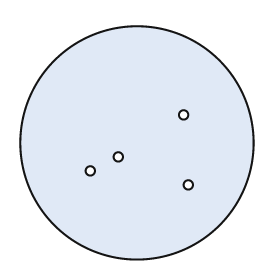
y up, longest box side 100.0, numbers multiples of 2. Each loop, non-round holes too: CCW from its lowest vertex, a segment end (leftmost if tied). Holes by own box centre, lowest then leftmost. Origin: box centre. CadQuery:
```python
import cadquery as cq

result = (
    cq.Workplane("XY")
    .moveTo(0.0, 0.0)
    .circle(50.0)
    .moveTo(22.0, -18.0)
    .circle(2.0)
    .moveTo(-20.0, -12.0)
    .circle(2.0)
    .moveTo(-8.0, -6.0)
    .circle(2.0)
    .moveTo(20.0, 12.0)
    .circle(2.0)
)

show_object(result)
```